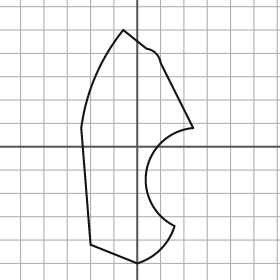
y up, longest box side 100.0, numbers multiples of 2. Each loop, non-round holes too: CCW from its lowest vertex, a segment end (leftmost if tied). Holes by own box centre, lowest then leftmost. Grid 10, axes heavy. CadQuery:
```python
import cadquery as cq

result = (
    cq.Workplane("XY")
    .moveTo(0.0, -50.0)
    .threePointArc((10.0, -44.0), (16.0, -34.0))
    .threePointArc((4.0, -10.0), (24.0, 8.0))
    .lineTo(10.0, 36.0)
    .threePointArc((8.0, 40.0), (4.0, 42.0))
    .lineTo(-6.0, 50.0)
    .threePointArc((-18.0, 30.0), (-24.0, 8.0))
    .lineTo(-20.0, -42.0)
    .close()
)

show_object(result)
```